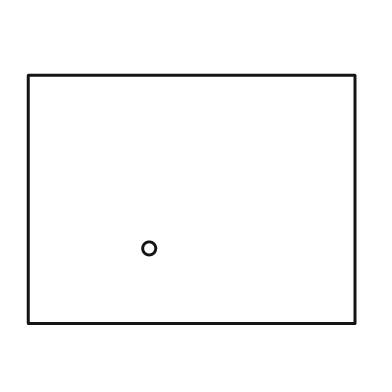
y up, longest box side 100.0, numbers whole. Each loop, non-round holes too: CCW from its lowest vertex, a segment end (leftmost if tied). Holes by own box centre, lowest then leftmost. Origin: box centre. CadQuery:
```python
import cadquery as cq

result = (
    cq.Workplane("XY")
    .moveTo(-50.0, -38.0)
    .lineTo(50.0, -38.0)
    .lineTo(50.0, 38.0)
    .lineTo(-50.0, 38.0)
    .close()
    .moveTo(-13.0, -15.0)
    .circle(2.0)
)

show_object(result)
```